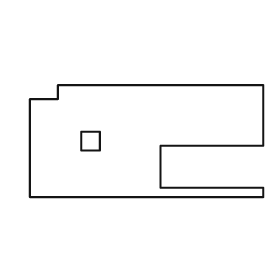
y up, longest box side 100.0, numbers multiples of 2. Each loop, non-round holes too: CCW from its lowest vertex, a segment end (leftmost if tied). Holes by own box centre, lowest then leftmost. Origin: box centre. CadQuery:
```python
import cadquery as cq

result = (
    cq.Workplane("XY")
    .moveTo(-50.0, -24.0)
    .lineTo(50.0, -24.0)
    .lineTo(50.0, -20.0)
    .lineTo(6.0, -20.0)
    .lineTo(6.0, -2.0)
    .lineTo(50.0, -2.0)
    .lineTo(50.0, 24.0)
    .lineTo(-38.0, 24.0)
    .lineTo(-38.0, 18.0)
    .lineTo(-50.0, 18.0)
    .close()
    .moveTo(-28.0, -4.0)
    .lineTo(-20.0, -4.0)
    .lineTo(-20.0, 4.0)
    .lineTo(-28.0, 4.0)
    .close()
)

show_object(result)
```